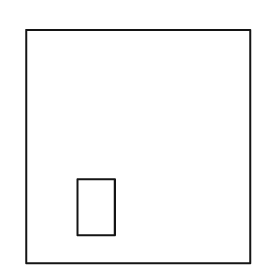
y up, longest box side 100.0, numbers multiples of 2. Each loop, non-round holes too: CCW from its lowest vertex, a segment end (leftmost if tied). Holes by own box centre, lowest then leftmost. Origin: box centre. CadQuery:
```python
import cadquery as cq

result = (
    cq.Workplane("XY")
    .moveTo(-48.0, -50.0)
    .lineTo(48.0, -50.0)
    .lineTo(48.0, 50.0)
    .lineTo(-48.0, 50.0)
    .close()
    .moveTo(-26.0, -38.0)
    .lineTo(-10.0, -38.0)
    .lineTo(-10.0, -14.0)
    .lineTo(-26.0, -14.0)
    .close()
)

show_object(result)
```